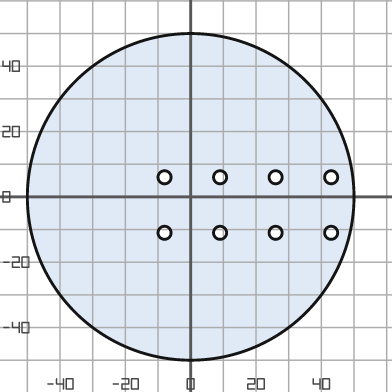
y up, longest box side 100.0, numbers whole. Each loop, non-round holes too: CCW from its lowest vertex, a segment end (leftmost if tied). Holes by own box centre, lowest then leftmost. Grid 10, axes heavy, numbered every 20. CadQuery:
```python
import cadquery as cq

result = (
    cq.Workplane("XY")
    .moveTo(0.0, 0.0)
    .circle(50.0)
    .moveTo(-8.0, -11.0)
    .circle(2.0)
    .moveTo(9.0, -11.0)
    .circle(2.0)
    .moveTo(26.0, -11.0)
    .circle(2.0)
    .moveTo(43.0, -11.0)
    .circle(2.0)
    .moveTo(-8.0, 6.0)
    .circle(2.0)
    .moveTo(9.0, 6.0)
    .circle(2.0)
    .moveTo(26.0, 6.0)
    .circle(2.0)
    .moveTo(43.0, 6.0)
    .circle(2.0)
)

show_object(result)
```